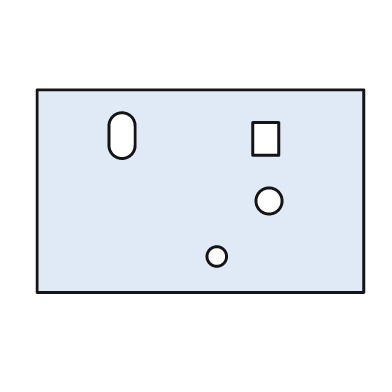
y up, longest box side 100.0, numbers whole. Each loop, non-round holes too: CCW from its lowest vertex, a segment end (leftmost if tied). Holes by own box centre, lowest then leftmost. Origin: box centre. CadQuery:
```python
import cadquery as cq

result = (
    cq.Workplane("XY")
    .moveTo(-50.0, -31.0)
    .lineTo(50.0, -31.0)
    .lineTo(50.0, 31.0)
    .lineTo(-50.0, 31.0)
    .close()
    .moveTo(5.0, -20.0)
    .circle(3.0)
    .moveTo(21.0, -3.0)
    .circle(4.0)
    .moveTo(16.0, 11.0)
    .lineTo(24.0, 11.0)
    .lineTo(24.0, 21.0)
    .lineTo(16.0, 21.0)
    .close()
    .moveTo(-28.0, 14.0)
    .threePointArc((-24.0, 10.0), (-20.0, 14.0))
    .lineTo(-20.0, 20.0)
    .threePointArc((-24.0, 24.0), (-28.0, 20.0))
    .close()
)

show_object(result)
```